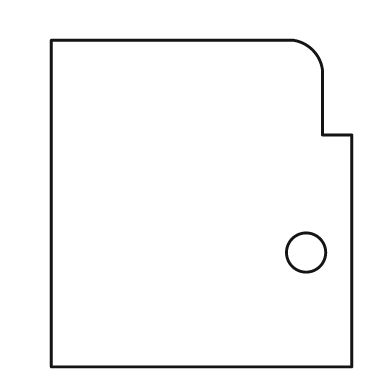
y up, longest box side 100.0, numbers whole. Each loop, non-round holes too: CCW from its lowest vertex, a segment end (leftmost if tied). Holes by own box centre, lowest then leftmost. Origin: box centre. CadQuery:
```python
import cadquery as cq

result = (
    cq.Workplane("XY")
    .moveTo(-46.0, -50.0)
    .lineTo(46.0, -50.0)
    .lineTo(46.0, 21.0)
    .lineTo(37.0, 21.0)
    .lineTo(37.0, 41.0)
    .threePointArc((34.0, 47.0), (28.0, 50.0))
    .lineTo(-46.0, 50.0)
    .close()
    .moveTo(32.0, -15.0)
    .circle(6.0)
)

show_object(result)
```